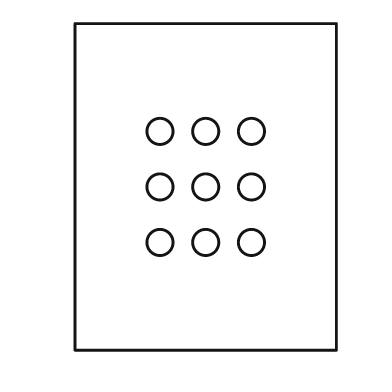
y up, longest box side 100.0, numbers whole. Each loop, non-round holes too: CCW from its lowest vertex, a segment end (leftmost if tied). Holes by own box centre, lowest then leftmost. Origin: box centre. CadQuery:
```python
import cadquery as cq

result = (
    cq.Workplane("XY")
    .moveTo(-40.0, -50.0)
    .lineTo(40.0, -50.0)
    .lineTo(40.0, 50.0)
    .lineTo(-40.0, 50.0)
    .close()
    .moveTo(-14.0, -17.0)
    .circle(4.0)
    .moveTo(0.0, -17.0)
    .circle(4.0)
    .moveTo(14.0, -17.0)
    .circle(4.0)
    .moveTo(-14.0, 0.0)
    .circle(4.0)
    .moveTo(0.0, 0.0)
    .circle(4.0)
    .moveTo(14.0, 0.0)
    .circle(4.0)
    .moveTo(-14.0, 17.0)
    .circle(4.0)
    .moveTo(0.0, 17.0)
    .circle(4.0)
    .moveTo(14.0, 17.0)
    .circle(4.0)
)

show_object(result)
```